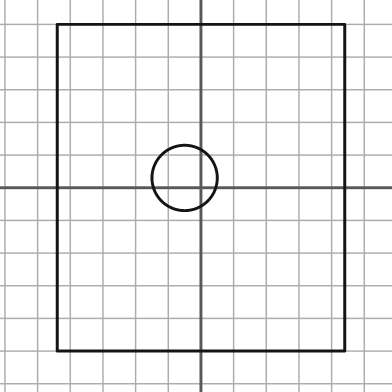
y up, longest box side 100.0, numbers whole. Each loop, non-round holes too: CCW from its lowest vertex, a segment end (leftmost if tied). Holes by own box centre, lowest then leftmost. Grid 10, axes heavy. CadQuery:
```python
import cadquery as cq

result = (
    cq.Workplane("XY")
    .moveTo(-44.0, -50.0)
    .lineTo(44.0, -50.0)
    .lineTo(44.0, 50.0)
    .lineTo(-44.0, 50.0)
    .close()
    .moveTo(-5.0, 3.0)
    .circle(10.0)
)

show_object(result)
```